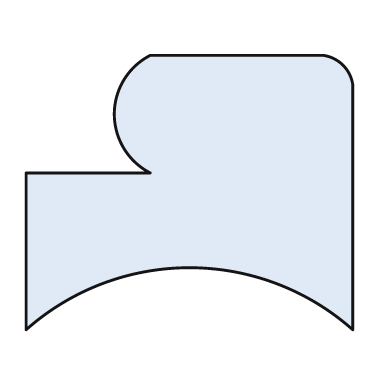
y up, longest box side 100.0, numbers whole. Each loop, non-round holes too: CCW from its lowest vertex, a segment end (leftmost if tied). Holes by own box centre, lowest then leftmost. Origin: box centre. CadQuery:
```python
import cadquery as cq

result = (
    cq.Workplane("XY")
    .moveTo(-50.0, -42.0)
    .threePointArc((0.0, -23.0), (50.0, -42.0))
    .lineTo(50.0, 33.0)
    .threePointArc((47.0, 39.0), (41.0, 42.0))
    .lineTo(-12.0, 42.0)
    .threePointArc((-23.0, 24.0), (-12.0, 6.0))
    .lineTo(-50.0, 6.0)
    .close()
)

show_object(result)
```